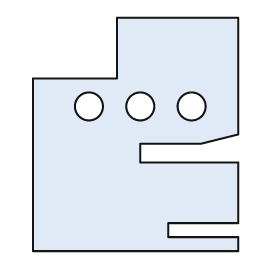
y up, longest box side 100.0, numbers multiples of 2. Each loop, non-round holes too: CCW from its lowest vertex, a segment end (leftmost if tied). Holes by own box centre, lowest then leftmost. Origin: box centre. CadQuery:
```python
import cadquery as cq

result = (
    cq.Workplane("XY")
    .moveTo(-44.0, -50.0)
    .lineTo(44.0, -50.0)
    .lineTo(44.0, -44.0)
    .lineTo(14.0, -44.0)
    .lineTo(14.0, -38.0)
    .lineTo(44.0, -38.0)
    .lineTo(44.0, -12.0)
    .lineTo(2.0, -12.0)
    .lineTo(2.0, -4.0)
    .lineTo(28.0, -4.0)
    .lineTo(44.0, 0.0)
    .lineTo(44.0, 50.0)
    .lineTo(-8.0, 50.0)
    .lineTo(-8.0, 24.0)
    .lineTo(-44.0, 24.0)
    .close()
    .moveTo(-20.0, 12.0)
    .circle(6.0)
    .moveTo(2.0, 12.0)
    .circle(6.0)
    .moveTo(24.0, 12.0)
    .circle(6.0)
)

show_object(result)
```